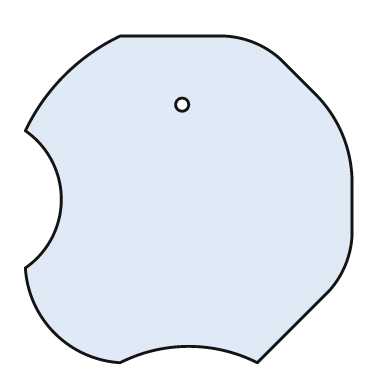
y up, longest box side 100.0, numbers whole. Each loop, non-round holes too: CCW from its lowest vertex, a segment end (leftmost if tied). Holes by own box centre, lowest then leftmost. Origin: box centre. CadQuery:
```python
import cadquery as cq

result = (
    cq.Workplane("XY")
    .moveTo(-21.0, -50.0)
    .threePointArc((0.0, -45.0), (21.0, -50.0))
    .lineTo(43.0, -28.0)
    .threePointArc((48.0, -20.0), (50.0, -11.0))
    .lineTo(50.0, 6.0)
    .threePointArc((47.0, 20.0), (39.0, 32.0))
    .lineTo(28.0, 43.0)
    .threePointArc((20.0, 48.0), (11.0, 50.0))
    .lineTo(-21.0, 50.0)
    .threePointArc((-38.0, 38.0), (-50.0, 21.0))
    .threePointArc((-39.0, 0.0), (-50.0, -21.0))
    .threePointArc((-41.0, -41.0), (-21.0, -50.0))
    .close()
    .moveTo(-2.0, 29.0)
    .circle(2.0)
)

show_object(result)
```